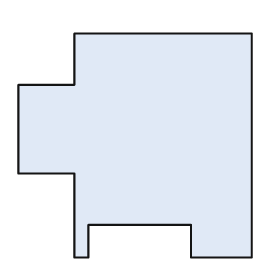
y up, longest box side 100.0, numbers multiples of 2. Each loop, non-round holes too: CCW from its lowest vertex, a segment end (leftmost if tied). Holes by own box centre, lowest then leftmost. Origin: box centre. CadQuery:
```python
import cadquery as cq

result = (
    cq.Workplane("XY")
    .moveTo(-26.0, -48.0)
    .lineTo(-20.0, -48.0)
    .lineTo(-20.0, -34.0)
    .lineTo(24.0, -34.0)
    .lineTo(24.0, -48.0)
    .lineTo(50.0, -48.0)
    .lineTo(50.0, 48.0)
    .lineTo(-26.0, 48.0)
    .lineTo(-26.0, 26.0)
    .lineTo(-50.0, 26.0)
    .lineTo(-50.0, -12.0)
    .lineTo(-26.0, -12.0)
    .close()
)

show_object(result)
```